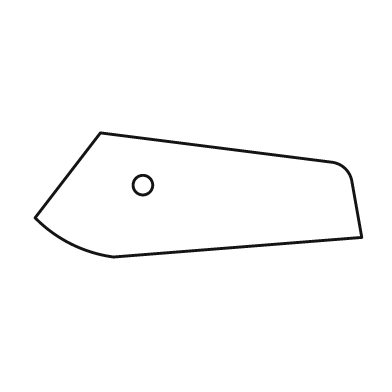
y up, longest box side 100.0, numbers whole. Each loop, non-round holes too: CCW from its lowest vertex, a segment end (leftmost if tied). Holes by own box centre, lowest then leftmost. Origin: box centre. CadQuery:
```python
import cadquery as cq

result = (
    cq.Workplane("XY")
    .moveTo(-26.0, -19.0)
    .lineTo(50.0, -13.0)
    .lineTo(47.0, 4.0)
    .threePointArc((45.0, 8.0), (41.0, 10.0))
    .lineTo(-30.0, 19.0)
    .lineTo(-50.0, -7.0)
    .threePointArc((-39.0, -15.0), (-26.0, -19.0))
    .close()
    .moveTo(-17.0, 3.0)
    .circle(3.0)
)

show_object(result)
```